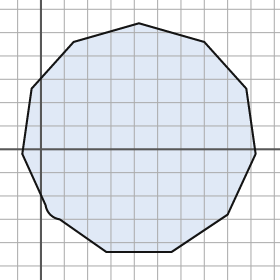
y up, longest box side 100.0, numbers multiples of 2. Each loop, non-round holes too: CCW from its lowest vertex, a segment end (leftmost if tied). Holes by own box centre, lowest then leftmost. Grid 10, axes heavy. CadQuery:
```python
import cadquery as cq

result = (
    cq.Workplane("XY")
    .moveTo(28.0, -44.0)
    .lineTo(56.0, -44.0)
    .lineTo(80.0, -28.0)
    .lineTo(92.0, -2.0)
    .lineTo(88.0, 26.0)
    .lineTo(70.0, 46.0)
    .lineTo(42.0, 54.0)
    .lineTo(14.0, 46.0)
    .lineTo(-4.0, 26.0)
    .lineTo(-8.0, -2.0)
    .lineTo(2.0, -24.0)
    .threePointArc((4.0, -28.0), (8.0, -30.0))
    .close()
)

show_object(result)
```